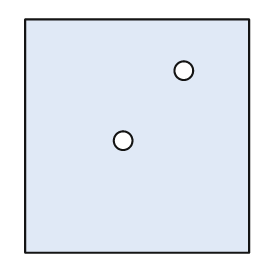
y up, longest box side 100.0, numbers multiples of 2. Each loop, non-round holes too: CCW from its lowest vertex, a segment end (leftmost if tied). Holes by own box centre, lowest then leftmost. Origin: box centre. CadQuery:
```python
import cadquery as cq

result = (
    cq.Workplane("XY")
    .moveTo(-48.0, -50.0)
    .lineTo(48.0, -50.0)
    .lineTo(48.0, 50.0)
    .lineTo(-48.0, 50.0)
    .close()
    .moveTo(-6.0, -2.0)
    .circle(4.0)
    .moveTo(20.0, 28.0)
    .circle(4.0)
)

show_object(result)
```